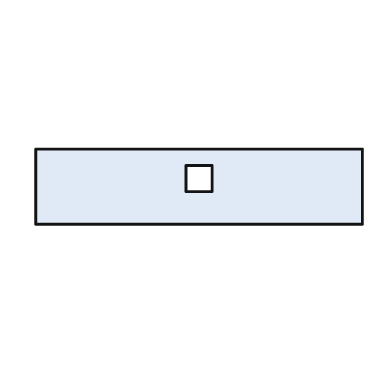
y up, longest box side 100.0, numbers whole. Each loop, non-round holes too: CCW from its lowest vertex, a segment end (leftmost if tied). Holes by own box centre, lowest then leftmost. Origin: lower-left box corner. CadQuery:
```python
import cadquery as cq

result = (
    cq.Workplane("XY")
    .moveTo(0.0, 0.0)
    .lineTo(100.0, 0.0)
    .lineTo(100.0, 23.0)
    .lineTo(0.0, 23.0)
    .close()
    .moveTo(46.0, 10.0)
    .lineTo(54.0, 10.0)
    .lineTo(54.0, 18.0)
    .lineTo(46.0, 18.0)
    .close()
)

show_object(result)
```